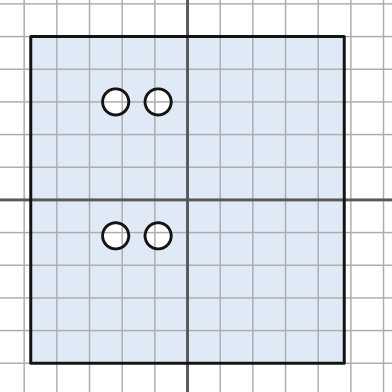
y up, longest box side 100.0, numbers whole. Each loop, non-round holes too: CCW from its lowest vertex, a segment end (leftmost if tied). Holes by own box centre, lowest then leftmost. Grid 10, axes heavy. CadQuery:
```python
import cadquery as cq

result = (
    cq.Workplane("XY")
    .moveTo(-48.0, -50.0)
    .lineTo(48.0, -50.0)
    .lineTo(48.0, 50.0)
    .lineTo(-48.0, 50.0)
    .close()
    .moveTo(-22.0, -11.0)
    .circle(4.0)
    .moveTo(-9.0, -11.0)
    .circle(4.0)
    .moveTo(-22.0, 30.0)
    .circle(4.0)
    .moveTo(-9.0, 30.0)
    .circle(4.0)
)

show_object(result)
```